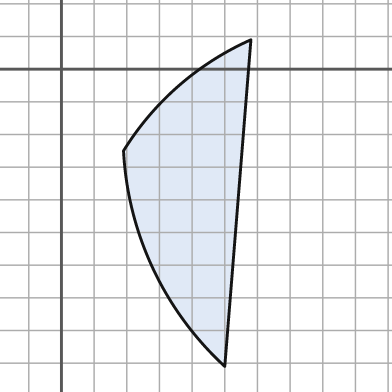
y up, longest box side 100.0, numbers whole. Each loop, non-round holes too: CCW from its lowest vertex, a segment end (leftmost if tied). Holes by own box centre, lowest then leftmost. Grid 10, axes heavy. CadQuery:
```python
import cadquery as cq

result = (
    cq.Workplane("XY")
    .moveTo(50.0, -91.0)
    .lineTo(58.0, 9.0)
    .threePointArc((36.0, -5.0), (19.0, -25.0))
    .threePointArc((28.0, -61.0), (50.0, -91.0))
    .close()
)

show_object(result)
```